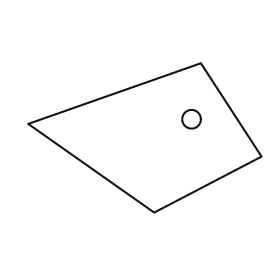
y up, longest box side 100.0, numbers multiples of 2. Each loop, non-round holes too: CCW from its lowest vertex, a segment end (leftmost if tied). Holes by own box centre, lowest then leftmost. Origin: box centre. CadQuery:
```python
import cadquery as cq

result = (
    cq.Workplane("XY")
    .moveTo(4.0, -32.0)
    .lineTo(50.0, -8.0)
    .lineTo(24.0, 32.0)
    .lineTo(-50.0, 6.0)
    .close()
    .moveTo(20.0, 8.0)
    .circle(4.0)
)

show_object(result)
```